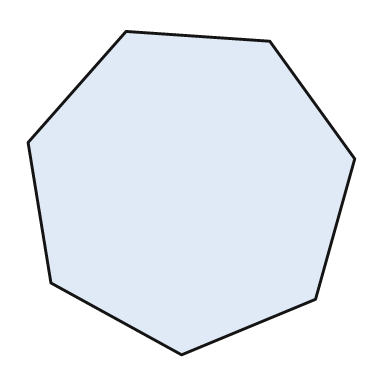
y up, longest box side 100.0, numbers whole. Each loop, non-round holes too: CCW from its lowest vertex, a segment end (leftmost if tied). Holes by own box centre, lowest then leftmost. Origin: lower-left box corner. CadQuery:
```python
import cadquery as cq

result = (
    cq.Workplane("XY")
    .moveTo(47.0, 0.0)
    .lineTo(88.0, 17.0)
    .lineTo(100.0, 60.0)
    .lineTo(74.0, 96.0)
    .lineTo(30.0, 99.0)
    .lineTo(0.0, 65.0)
    .lineTo(7.0, 22.0)
    .close()
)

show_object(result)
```